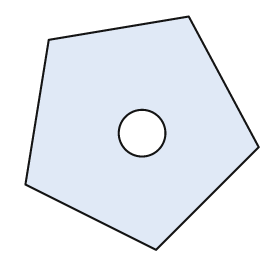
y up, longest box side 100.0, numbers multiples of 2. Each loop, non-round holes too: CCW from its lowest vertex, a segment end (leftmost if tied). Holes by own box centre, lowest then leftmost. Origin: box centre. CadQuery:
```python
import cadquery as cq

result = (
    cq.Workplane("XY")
    .moveTo(6.0, -50.0)
    .lineTo(50.0, -6.0)
    .lineTo(20.0, 50.0)
    .lineTo(-40.0, 40.0)
    .lineTo(-50.0, -22.0)
    .close()
    .moveTo(0.0, 0.0)
    .circle(10.0)
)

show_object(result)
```